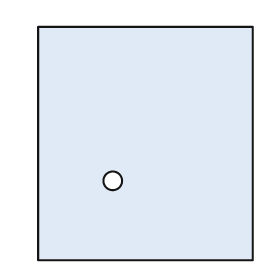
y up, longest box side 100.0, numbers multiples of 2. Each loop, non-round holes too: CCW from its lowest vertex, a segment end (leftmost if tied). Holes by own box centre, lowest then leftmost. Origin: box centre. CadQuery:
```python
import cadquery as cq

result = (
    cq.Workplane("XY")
    .moveTo(-46.0, -50.0)
    .lineTo(46.0, -50.0)
    .lineTo(46.0, 50.0)
    .lineTo(-46.0, 50.0)
    .close()
    .moveTo(-14.0, -16.0)
    .circle(4.0)
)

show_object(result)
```